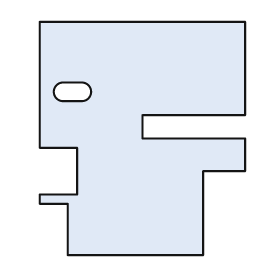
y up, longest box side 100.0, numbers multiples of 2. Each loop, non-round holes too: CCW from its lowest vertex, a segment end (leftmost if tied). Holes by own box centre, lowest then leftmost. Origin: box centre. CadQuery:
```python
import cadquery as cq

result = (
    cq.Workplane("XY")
    .moveTo(-32.0, -50.0)
    .lineTo(26.0, -50.0)
    .lineTo(26.0, -14.0)
    .lineTo(44.0, -14.0)
    .lineTo(44.0, 0.0)
    .lineTo(0.0, 0.0)
    .lineTo(0.0, 10.0)
    .lineTo(44.0, 10.0)
    .lineTo(44.0, 50.0)
    .lineTo(-44.0, 50.0)
    .lineTo(-44.0, -4.0)
    .lineTo(-28.0, -4.0)
    .lineTo(-28.0, -24.0)
    .lineTo(-44.0, -24.0)
    .lineTo(-44.0, -28.0)
    .lineTo(-32.0, -28.0)
    .close()
    .moveTo(-34.0, 16.0)
    .lineTo(-26.0, 16.0)
    .threePointArc((-22.0, 20.0), (-26.0, 24.0))
    .lineTo(-34.0, 24.0)
    .threePointArc((-38.0, 20.0), (-34.0, 16.0))
    .close()
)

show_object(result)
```